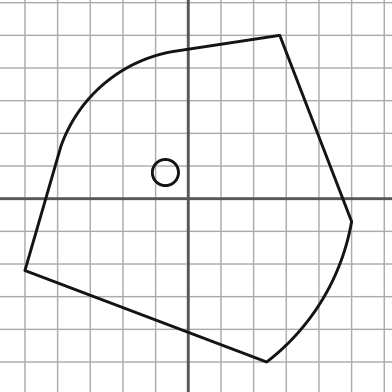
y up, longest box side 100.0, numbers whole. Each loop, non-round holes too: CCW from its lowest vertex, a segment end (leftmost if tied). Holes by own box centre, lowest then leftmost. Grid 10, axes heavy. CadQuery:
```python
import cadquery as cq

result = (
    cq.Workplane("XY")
    .moveTo(24.0, -50.0)
    .threePointArc((41.0, -31.0), (50.0, -7.0))
    .lineTo(28.0, 50.0)
    .lineTo(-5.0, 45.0)
    .threePointArc((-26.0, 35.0), (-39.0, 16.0))
    .lineTo(-50.0, -22.0)
    .close()
    .moveTo(-7.0, 8.0)
    .circle(4.0)
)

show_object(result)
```